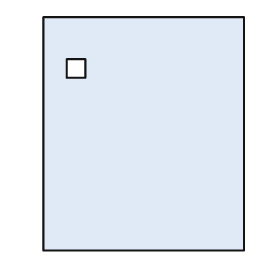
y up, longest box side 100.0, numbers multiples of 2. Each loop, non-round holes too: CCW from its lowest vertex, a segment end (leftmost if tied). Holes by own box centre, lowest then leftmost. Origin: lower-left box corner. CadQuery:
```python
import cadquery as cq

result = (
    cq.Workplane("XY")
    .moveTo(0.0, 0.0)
    .lineTo(86.0, 0.0)
    .lineTo(86.0, 100.0)
    .lineTo(0.0, 100.0)
    .close()
    .moveTo(10.0, 74.0)
    .lineTo(18.0, 74.0)
    .lineTo(18.0, 82.0)
    .lineTo(10.0, 82.0)
    .close()
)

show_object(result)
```